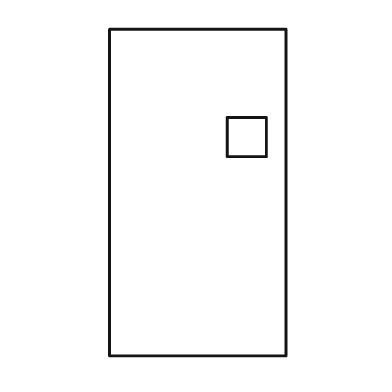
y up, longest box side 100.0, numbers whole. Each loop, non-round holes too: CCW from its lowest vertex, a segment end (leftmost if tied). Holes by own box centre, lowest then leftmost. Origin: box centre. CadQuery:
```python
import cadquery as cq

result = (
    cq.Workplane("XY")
    .moveTo(-27.0, -50.0)
    .lineTo(27.0, -50.0)
    .lineTo(27.0, 50.0)
    .lineTo(-27.0, 50.0)
    .close()
    .moveTo(9.0, 11.0)
    .lineTo(21.0, 11.0)
    .lineTo(21.0, 23.0)
    .lineTo(9.0, 23.0)
    .close()
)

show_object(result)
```